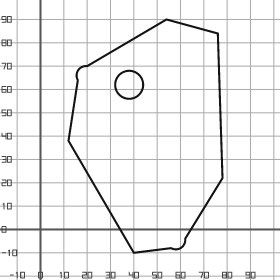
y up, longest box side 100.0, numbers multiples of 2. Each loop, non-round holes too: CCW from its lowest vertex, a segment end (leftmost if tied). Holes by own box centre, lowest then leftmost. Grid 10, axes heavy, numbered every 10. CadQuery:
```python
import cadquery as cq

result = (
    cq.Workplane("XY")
    .moveTo(40.0, -10.0)
    .lineTo(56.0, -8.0)
    .threePointArc((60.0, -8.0), (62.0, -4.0))
    .lineTo(78.0, 22.0)
    .lineTo(76.0, 84.0)
    .lineTo(54.0, 90.0)
    .lineTo(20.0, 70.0)
    .threePointArc((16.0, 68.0), (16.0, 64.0))
    .lineTo(12.0, 38.0)
    .close()
    .moveTo(38.0, 62.0)
    .circle(6.0)
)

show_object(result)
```